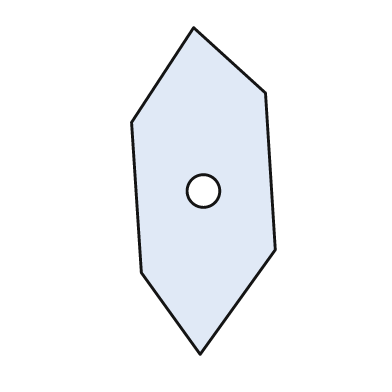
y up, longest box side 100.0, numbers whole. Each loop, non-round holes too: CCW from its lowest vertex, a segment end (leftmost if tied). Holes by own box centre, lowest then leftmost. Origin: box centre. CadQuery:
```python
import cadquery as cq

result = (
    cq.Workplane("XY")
    .moveTo(-1.0, -50.0)
    .lineTo(22.0, -18.0)
    .lineTo(19.0, 30.0)
    .lineTo(-3.0, 50.0)
    .lineTo(-22.0, 21.0)
    .lineTo(-19.0, -25.0)
    .close()
    .moveTo(0.0, 0.0)
    .circle(5.0)
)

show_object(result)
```